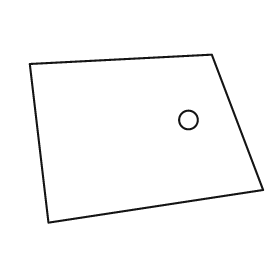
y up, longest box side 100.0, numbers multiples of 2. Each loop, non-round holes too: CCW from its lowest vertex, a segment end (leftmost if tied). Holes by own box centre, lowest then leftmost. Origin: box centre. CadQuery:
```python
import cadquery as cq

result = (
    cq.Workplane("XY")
    .moveTo(-42.0, -36.0)
    .lineTo(50.0, -22.0)
    .lineTo(28.0, 36.0)
    .lineTo(-50.0, 32.0)
    .close()
    .moveTo(18.0, 8.0)
    .circle(4.0)
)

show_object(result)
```